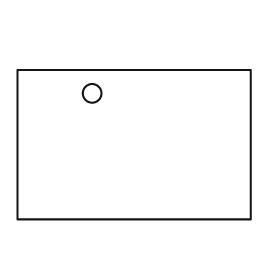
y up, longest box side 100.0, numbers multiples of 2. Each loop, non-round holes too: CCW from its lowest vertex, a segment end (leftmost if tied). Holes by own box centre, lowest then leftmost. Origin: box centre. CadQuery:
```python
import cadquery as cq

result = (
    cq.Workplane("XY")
    .moveTo(-50.0, -32.0)
    .lineTo(50.0, -32.0)
    .lineTo(50.0, 32.0)
    .lineTo(-50.0, 32.0)
    .close()
    .moveTo(-18.0, 22.0)
    .circle(4.0)
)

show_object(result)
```